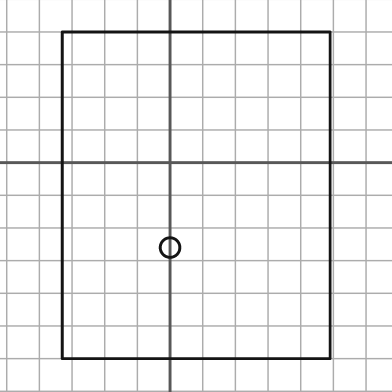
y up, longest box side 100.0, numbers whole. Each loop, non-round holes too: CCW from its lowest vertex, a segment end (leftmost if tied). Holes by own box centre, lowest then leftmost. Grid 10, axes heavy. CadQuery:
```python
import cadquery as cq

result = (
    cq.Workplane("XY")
    .moveTo(-33.0, -60.0)
    .lineTo(49.0, -60.0)
    .lineTo(49.0, 40.0)
    .lineTo(-33.0, 40.0)
    .close()
    .moveTo(0.0, -26.0)
    .circle(3.0)
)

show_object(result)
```